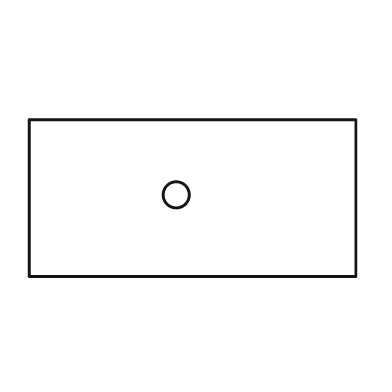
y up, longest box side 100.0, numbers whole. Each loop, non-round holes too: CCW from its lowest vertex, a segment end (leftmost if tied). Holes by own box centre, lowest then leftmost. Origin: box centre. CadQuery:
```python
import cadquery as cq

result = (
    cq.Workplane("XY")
    .moveTo(-50.0, -24.0)
    .lineTo(50.0, -24.0)
    .lineTo(50.0, 24.0)
    .lineTo(-50.0, 24.0)
    .close()
    .moveTo(-5.0, 1.0)
    .circle(4.0)
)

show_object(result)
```